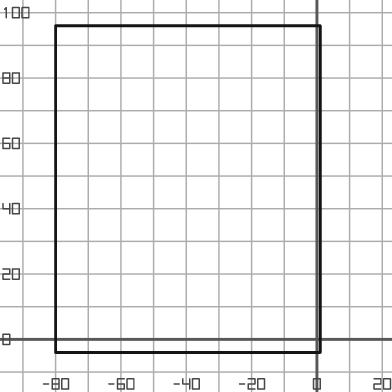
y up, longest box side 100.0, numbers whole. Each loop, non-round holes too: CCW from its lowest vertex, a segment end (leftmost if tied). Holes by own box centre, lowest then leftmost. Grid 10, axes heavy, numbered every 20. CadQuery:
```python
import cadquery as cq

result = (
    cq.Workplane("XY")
    .moveTo(-80.0, -4.0)
    .lineTo(1.0, -4.0)
    .lineTo(1.0, 96.0)
    .lineTo(-80.0, 96.0)
    .close()
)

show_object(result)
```